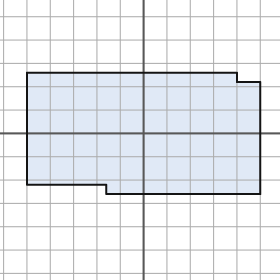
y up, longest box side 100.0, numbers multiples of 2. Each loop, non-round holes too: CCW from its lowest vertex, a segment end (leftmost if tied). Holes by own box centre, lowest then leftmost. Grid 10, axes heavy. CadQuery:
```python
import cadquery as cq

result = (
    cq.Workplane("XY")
    .moveTo(-16.0, -26.0)
    .lineTo(50.0, -26.0)
    .lineTo(50.0, 22.0)
    .lineTo(40.0, 22.0)
    .lineTo(40.0, 26.0)
    .lineTo(-50.0, 26.0)
    .lineTo(-50.0, -22.0)
    .lineTo(-16.0, -22.0)
    .close()
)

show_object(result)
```